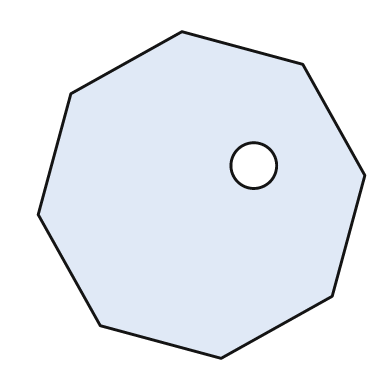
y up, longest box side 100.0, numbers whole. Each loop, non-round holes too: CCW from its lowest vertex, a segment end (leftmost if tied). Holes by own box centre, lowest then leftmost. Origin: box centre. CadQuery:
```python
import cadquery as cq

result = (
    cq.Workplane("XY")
    .moveTo(6.0, -50.0)
    .lineTo(40.0, -31.0)
    .lineTo(50.0, 6.0)
    .lineTo(31.0, 40.0)
    .lineTo(-6.0, 50.0)
    .lineTo(-40.0, 31.0)
    .lineTo(-50.0, -6.0)
    .lineTo(-31.0, -40.0)
    .close()
    .moveTo(16.0, 9.0)
    .circle(7.0)
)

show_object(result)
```